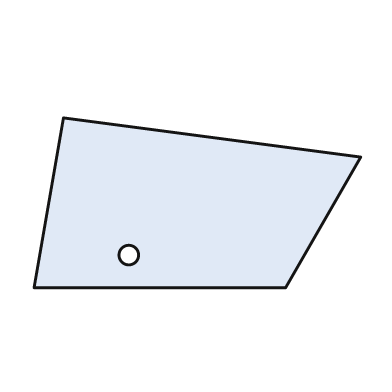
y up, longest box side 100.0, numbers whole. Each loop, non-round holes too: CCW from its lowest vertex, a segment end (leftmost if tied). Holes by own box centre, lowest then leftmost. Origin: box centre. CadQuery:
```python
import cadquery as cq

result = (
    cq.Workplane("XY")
    .moveTo(-50.0, -26.0)
    .lineTo(27.0, -26.0)
    .lineTo(50.0, 14.0)
    .lineTo(-41.0, 26.0)
    .close()
    .moveTo(-21.0, -16.0)
    .circle(3.0)
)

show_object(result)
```